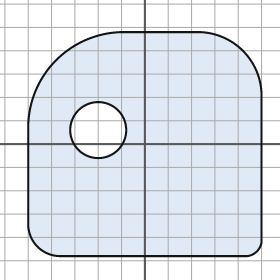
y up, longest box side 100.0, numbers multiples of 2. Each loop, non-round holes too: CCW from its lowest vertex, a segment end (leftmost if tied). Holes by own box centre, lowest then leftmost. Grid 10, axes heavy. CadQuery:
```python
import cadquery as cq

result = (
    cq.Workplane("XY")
    .moveTo(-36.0, -48.0)
    .lineTo(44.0, -48.0)
    .threePointArc((48.0, -46.0), (50.0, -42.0))
    .lineTo(50.0, 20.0)
    .threePointArc((42.0, 40.0), (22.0, 48.0))
    .lineTo(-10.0, 48.0)
    .threePointArc((-38.0, 36.0), (-50.0, 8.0))
    .lineTo(-50.0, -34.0)
    .threePointArc((-46.0, -44.0), (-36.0, -48.0))
    .close()
    .moveTo(-20.0, 6.0)
    .circle(12.0)
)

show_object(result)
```